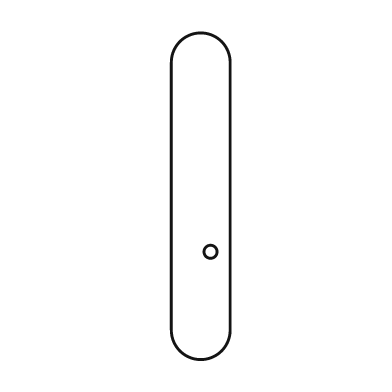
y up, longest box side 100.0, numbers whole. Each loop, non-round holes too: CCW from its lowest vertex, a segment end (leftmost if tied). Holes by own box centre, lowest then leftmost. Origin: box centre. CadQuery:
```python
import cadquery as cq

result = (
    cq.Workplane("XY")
    .moveTo(-9.0, -41.0)
    .threePointArc((0.0, -50.0), (9.0, -41.0))
    .lineTo(9.0, 41.0)
    .threePointArc((0.0, 50.0), (-9.0, 41.0))
    .close()
    .moveTo(3.0, -17.0)
    .circle(2.0)
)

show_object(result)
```